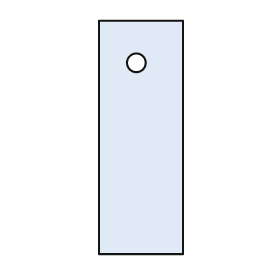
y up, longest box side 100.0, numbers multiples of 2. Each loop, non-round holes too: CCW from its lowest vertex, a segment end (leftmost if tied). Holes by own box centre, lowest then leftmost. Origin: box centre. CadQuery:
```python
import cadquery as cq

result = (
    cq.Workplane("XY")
    .moveTo(-18.0, -50.0)
    .lineTo(18.0, -50.0)
    .lineTo(18.0, 50.0)
    .lineTo(-18.0, 50.0)
    .close()
    .moveTo(-2.0, 32.0)
    .circle(4.0)
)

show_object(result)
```